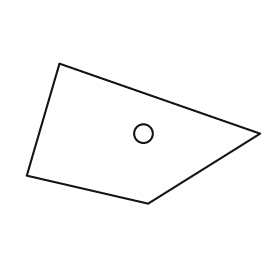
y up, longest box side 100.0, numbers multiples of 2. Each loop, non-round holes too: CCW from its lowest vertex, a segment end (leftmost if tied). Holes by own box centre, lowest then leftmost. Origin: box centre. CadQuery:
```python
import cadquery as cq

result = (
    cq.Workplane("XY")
    .moveTo(2.0, -30.0)
    .lineTo(50.0, 0.0)
    .lineTo(-36.0, 30.0)
    .lineTo(-50.0, -18.0)
    .close()
    .moveTo(0.0, 0.0)
    .circle(4.0)
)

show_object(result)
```